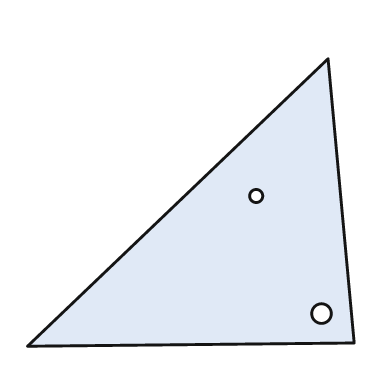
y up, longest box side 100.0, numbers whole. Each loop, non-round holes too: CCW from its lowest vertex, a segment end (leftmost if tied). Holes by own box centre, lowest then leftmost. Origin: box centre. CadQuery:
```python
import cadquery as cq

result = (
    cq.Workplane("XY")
    .moveTo(-50.0, -44.0)
    .lineTo(50.0, -43.0)
    .lineTo(42.0, 44.0)
    .close()
    .moveTo(40.0, -34.0)
    .circle(3.0)
    .moveTo(20.0, 2.0)
    .circle(2.0)
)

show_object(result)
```